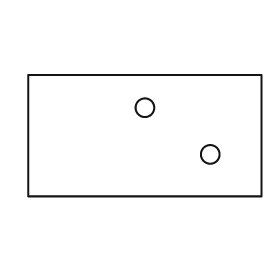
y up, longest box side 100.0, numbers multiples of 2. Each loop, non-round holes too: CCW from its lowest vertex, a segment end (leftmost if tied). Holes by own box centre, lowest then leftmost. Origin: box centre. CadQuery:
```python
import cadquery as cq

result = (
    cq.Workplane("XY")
    .moveTo(-50.0, -26.0)
    .lineTo(50.0, -26.0)
    .lineTo(50.0, 26.0)
    .lineTo(-50.0, 26.0)
    .close()
    .moveTo(28.0, -8.0)
    .circle(4.0)
    .moveTo(0.0, 12.0)
    .circle(4.0)
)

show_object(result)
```